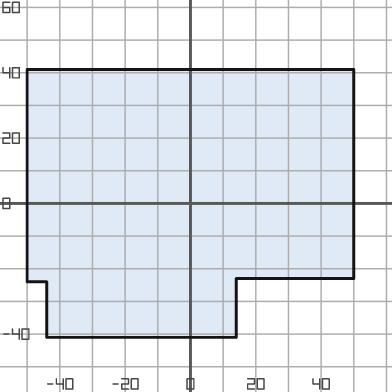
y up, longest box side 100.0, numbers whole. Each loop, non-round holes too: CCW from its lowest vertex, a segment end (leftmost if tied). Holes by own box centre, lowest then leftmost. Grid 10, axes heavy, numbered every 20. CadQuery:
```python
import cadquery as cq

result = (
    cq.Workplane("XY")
    .moveTo(-44.0, -41.0)
    .lineTo(14.0, -41.0)
    .lineTo(14.0, -23.0)
    .lineTo(50.0, -23.0)
    .lineTo(50.0, 41.0)
    .lineTo(-50.0, 41.0)
    .lineTo(-50.0, -24.0)
    .lineTo(-44.0, -24.0)
    .close()
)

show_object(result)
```